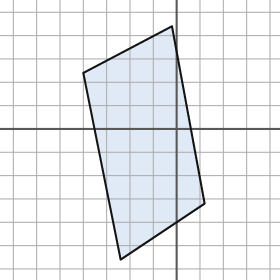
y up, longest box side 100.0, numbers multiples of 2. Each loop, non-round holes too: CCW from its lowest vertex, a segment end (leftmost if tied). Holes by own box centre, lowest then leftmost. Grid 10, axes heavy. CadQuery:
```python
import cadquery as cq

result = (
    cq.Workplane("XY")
    .moveTo(-24.0, -56.0)
    .lineTo(12.0, -32.0)
    .lineTo(-2.0, 44.0)
    .lineTo(-40.0, 24.0)
    .close()
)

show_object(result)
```